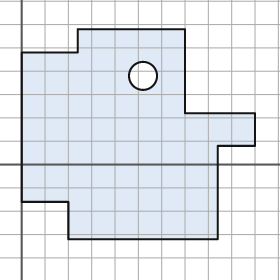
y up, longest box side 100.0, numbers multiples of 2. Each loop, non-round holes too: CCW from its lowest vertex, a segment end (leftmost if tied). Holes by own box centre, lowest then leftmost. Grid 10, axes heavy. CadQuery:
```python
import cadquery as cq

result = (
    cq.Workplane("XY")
    .moveTo(20.0, -32.0)
    .lineTo(84.0, -32.0)
    .lineTo(84.0, 8.0)
    .lineTo(100.0, 8.0)
    .lineTo(100.0, 22.0)
    .lineTo(70.0, 22.0)
    .lineTo(70.0, 58.0)
    .lineTo(24.0, 58.0)
    .lineTo(24.0, 48.0)
    .lineTo(0.0, 48.0)
    .lineTo(0.0, -16.0)
    .lineTo(20.0, -16.0)
    .close()
    .moveTo(52.0, 38.0)
    .circle(6.0)
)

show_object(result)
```